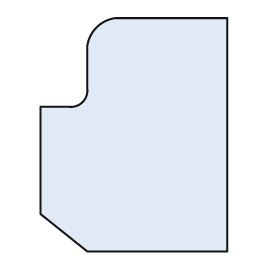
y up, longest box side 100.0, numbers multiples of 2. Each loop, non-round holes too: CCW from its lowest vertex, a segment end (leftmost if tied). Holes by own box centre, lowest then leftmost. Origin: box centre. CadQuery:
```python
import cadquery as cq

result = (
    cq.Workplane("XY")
    .moveTo(-20.0, -50.0)
    .lineTo(40.0, -50.0)
    .lineTo(40.0, 50.0)
    .lineTo(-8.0, 50.0)
    .threePointArc((-16.0, 46.0), (-20.0, 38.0))
    .lineTo(-20.0, 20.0)
    .threePointArc((-22.0, 14.0), (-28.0, 12.0))
    .lineTo(-40.0, 12.0)
    .lineTo(-40.0, -34.0)
    .close()
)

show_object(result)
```